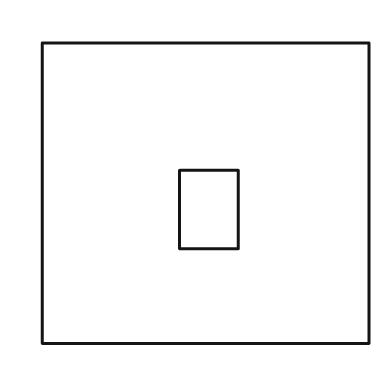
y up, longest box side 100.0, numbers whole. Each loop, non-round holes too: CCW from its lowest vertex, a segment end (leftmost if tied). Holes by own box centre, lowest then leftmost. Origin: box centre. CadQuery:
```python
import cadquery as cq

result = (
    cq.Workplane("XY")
    .moveTo(-50.0, -46.0)
    .lineTo(50.0, -46.0)
    .lineTo(50.0, 46.0)
    .lineTo(-50.0, 46.0)
    .close()
    .moveTo(-8.0, -17.0)
    .lineTo(10.0, -17.0)
    .lineTo(10.0, 7.0)
    .lineTo(-8.0, 7.0)
    .close()
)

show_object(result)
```